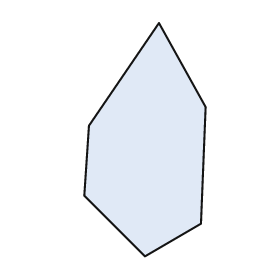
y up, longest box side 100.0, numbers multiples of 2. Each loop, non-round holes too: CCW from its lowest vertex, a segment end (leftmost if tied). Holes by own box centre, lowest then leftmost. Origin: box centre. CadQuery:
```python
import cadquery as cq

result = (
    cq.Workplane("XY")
    .moveTo(0.0, -50.0)
    .lineTo(24.0, -36.0)
    .lineTo(26.0, 14.0)
    .lineTo(6.0, 50.0)
    .lineTo(-24.0, 6.0)
    .lineTo(-26.0, -24.0)
    .close()
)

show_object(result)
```